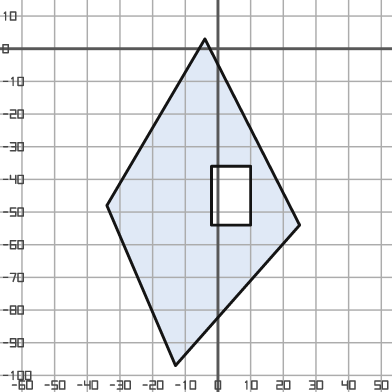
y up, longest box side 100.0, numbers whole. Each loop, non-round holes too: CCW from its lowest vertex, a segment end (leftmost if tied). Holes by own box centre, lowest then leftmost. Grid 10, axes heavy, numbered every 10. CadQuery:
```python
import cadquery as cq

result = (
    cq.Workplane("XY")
    .moveTo(-13.0, -97.0)
    .lineTo(25.0, -54.0)
    .lineTo(-4.0, 3.0)
    .lineTo(-34.0, -48.0)
    .close()
    .moveTo(-2.0, -54.0)
    .lineTo(10.0, -54.0)
    .lineTo(10.0, -36.0)
    .lineTo(-2.0, -36.0)
    .close()
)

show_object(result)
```